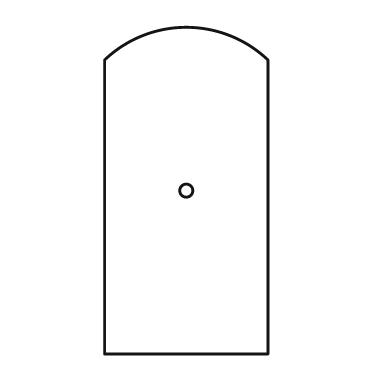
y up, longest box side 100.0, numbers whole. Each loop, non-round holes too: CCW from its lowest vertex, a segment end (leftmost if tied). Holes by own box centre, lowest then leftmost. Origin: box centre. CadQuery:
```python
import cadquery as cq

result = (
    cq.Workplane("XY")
    .moveTo(-25.0, -50.0)
    .lineTo(25.0, -50.0)
    .lineTo(25.0, 40.0)
    .threePointArc((0.0, 50.0), (-25.0, 40.0))
    .close()
    .moveTo(0.0, 0.0)
    .circle(2.0)
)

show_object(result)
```